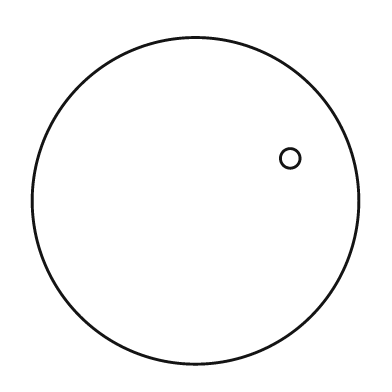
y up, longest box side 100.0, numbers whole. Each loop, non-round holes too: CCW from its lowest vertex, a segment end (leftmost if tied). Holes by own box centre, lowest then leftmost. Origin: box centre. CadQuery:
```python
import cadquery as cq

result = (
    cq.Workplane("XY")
    .moveTo(0.0, 0.0)
    .circle(50.0)
    .moveTo(29.0, 13.0)
    .circle(3.0)
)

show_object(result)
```